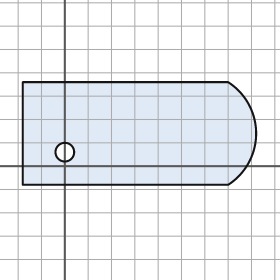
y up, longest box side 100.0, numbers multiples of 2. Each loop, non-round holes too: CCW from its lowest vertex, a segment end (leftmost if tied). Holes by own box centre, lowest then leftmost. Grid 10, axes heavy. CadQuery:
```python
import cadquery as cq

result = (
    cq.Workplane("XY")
    .moveTo(-18.0, -8.0)
    .lineTo(70.0, -8.0)
    .threePointArc((82.0, 14.0), (70.0, 36.0))
    .lineTo(-18.0, 36.0)
    .close()
    .moveTo(0.0, 6.0)
    .circle(4.0)
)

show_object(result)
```